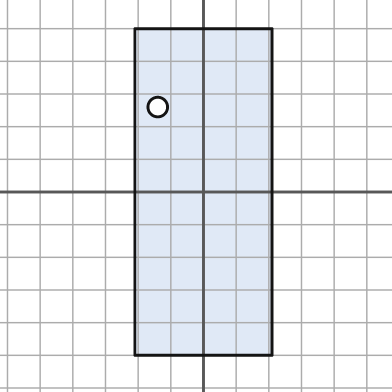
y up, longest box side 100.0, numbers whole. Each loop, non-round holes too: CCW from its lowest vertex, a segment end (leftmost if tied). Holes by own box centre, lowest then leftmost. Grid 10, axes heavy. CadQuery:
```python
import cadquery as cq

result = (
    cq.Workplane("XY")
    .moveTo(-21.0, -50.0)
    .lineTo(21.0, -50.0)
    .lineTo(21.0, 50.0)
    .lineTo(-21.0, 50.0)
    .close()
    .moveTo(-14.0, 26.0)
    .circle(3.0)
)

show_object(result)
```